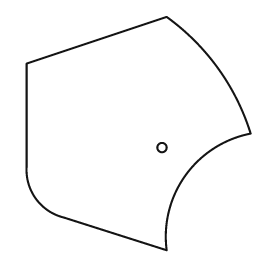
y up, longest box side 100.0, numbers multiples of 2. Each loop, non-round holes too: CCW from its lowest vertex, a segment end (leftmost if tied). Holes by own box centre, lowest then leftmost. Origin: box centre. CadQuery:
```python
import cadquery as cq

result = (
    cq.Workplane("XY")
    .moveTo(12.0, -50.0)
    .threePointArc((20.0, -18.0), (48.0, 0.0))
    .threePointArc((34.0, 28.0), (12.0, 50.0))
    .lineTo(-48.0, 30.0)
    .lineTo(-48.0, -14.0)
    .threePointArc((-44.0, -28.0), (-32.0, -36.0))
    .close()
    .moveTo(10.0, -6.0)
    .circle(2.0)
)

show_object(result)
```